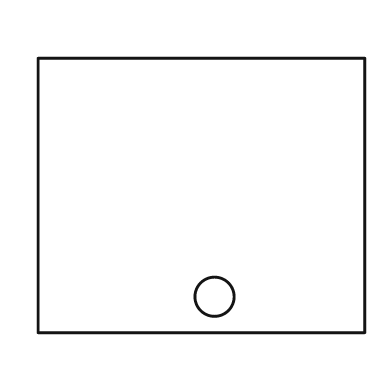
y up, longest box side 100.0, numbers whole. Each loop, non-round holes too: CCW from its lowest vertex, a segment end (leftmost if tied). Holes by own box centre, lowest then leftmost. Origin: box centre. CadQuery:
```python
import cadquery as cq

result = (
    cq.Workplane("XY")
    .moveTo(-50.0, -42.0)
    .lineTo(50.0, -42.0)
    .lineTo(50.0, 42.0)
    .lineTo(-50.0, 42.0)
    .close()
    .moveTo(4.0, -31.0)
    .circle(6.0)
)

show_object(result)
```